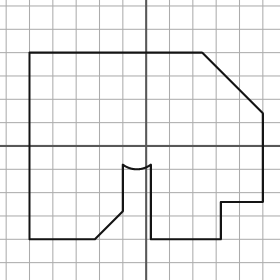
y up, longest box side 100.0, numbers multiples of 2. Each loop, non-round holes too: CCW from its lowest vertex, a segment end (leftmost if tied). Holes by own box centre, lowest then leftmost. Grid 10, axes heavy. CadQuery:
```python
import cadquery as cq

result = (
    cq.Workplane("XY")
    .moveTo(-50.0, -40.0)
    .lineTo(-22.0, -40.0)
    .lineTo(-10.0, -28.0)
    .lineTo(-10.0, -8.0)
    .threePointArc((-4.0, -10.0), (2.0, -8.0))
    .lineTo(2.0, -40.0)
    .lineTo(32.0, -40.0)
    .lineTo(32.0, -24.0)
    .lineTo(50.0, -24.0)
    .lineTo(50.0, 14.0)
    .lineTo(24.0, 40.0)
    .lineTo(-50.0, 40.0)
    .close()
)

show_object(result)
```